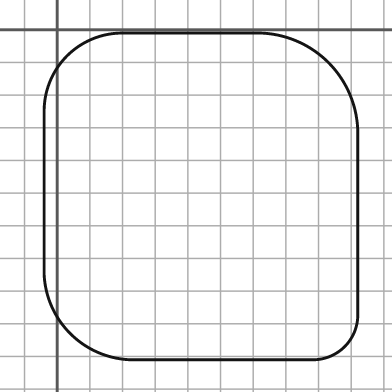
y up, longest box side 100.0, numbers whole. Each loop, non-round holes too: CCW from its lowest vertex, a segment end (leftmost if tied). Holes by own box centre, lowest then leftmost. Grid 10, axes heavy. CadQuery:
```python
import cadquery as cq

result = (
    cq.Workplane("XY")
    .moveTo(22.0, -101.0)
    .lineTo(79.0, -101.0)
    .threePointArc((88.0, -97.0), (92.0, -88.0))
    .lineTo(92.0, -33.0)
    .threePointArc((83.0, -10.0), (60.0, -1.0))
    .lineTo(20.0, -1.0)
    .threePointArc((3.0, -8.0), (-4.0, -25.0))
    .lineTo(-4.0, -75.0)
    .threePointArc((4.0, -93.0), (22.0, -101.0))
    .close()
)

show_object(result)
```